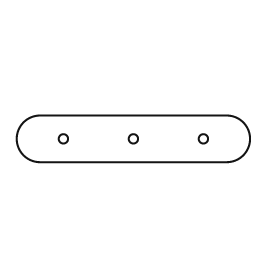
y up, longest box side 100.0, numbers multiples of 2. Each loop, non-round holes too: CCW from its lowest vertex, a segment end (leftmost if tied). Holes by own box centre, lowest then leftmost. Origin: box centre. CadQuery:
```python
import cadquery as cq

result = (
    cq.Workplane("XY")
    .moveTo(-40.0, -10.0)
    .lineTo(40.0, -10.0)
    .threePointArc((50.0, 0.0), (40.0, 10.0))
    .lineTo(-40.0, 10.0)
    .threePointArc((-50.0, 0.0), (-40.0, -10.0))
    .close()
    .moveTo(-30.0, 0.0)
    .circle(2.0)
    .moveTo(0.0, 0.0)
    .circle(2.0)
    .moveTo(30.0, 0.0)
    .circle(2.0)
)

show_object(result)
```